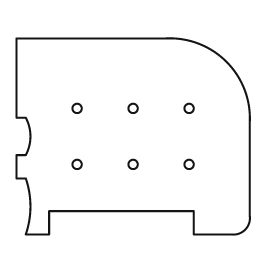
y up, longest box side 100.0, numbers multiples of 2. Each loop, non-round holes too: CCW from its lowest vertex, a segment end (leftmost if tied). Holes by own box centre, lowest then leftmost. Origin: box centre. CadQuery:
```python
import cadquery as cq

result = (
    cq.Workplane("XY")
    .moveTo(-46.0, -42.0)
    .lineTo(-36.0, -42.0)
    .lineTo(-36.0, -32.0)
    .lineTo(26.0, -32.0)
    .lineTo(26.0, -42.0)
    .lineTo(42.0, -42.0)
    .threePointArc((48.0, -40.0), (50.0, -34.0))
    .lineTo(50.0, 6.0)
    .threePointArc((40.0, 32.0), (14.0, 42.0))
    .lineTo(-50.0, 42.0)
    .lineTo(-50.0, 8.0)
    .lineTo(-46.0, 8.0)
    .threePointArc((-44.0, 0.0), (-46.0, -8.0))
    .lineTo(-50.0, -8.0)
    .lineTo(-50.0, -18.0)
    .lineTo(-46.0, -18.0)
    .threePointArc((-44.0, -30.0), (-46.0, -42.0))
    .close()
    .moveTo(-24.0, -12.0)
    .circle(2.0)
    .moveTo(0.0, -12.0)
    .circle(2.0)
    .moveTo(24.0, -12.0)
    .circle(2.0)
    .moveTo(-24.0, 12.0)
    .circle(2.0)
    .moveTo(0.0, 12.0)
    .circle(2.0)
    .moveTo(24.0, 12.0)
    .circle(2.0)
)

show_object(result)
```